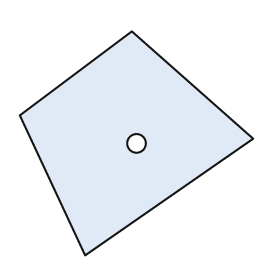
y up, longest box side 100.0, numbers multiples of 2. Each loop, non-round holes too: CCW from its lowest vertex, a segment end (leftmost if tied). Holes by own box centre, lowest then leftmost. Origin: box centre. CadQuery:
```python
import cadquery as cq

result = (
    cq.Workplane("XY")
    .moveTo(-22.0, -48.0)
    .lineTo(50.0, 2.0)
    .lineTo(-2.0, 48.0)
    .lineTo(-50.0, 12.0)
    .close()
    .moveTo(0.0, 0.0)
    .circle(4.0)
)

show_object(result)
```